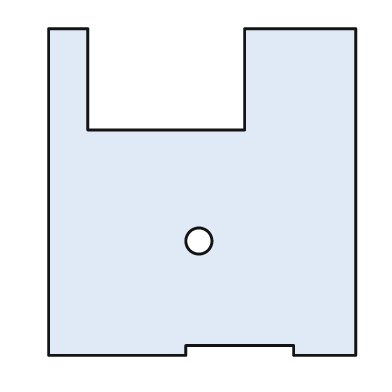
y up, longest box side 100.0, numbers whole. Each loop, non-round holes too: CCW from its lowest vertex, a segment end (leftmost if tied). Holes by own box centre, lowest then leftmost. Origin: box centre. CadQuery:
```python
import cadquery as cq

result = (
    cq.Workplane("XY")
    .moveTo(-47.0, -50.0)
    .lineTo(-5.0, -50.0)
    .lineTo(-5.0, -47.0)
    .lineTo(28.0, -47.0)
    .lineTo(28.0, -50.0)
    .lineTo(47.0, -50.0)
    .lineTo(47.0, 50.0)
    .lineTo(13.0, 50.0)
    .lineTo(13.0, 19.0)
    .lineTo(-35.0, 19.0)
    .lineTo(-35.0, 50.0)
    .lineTo(-47.0, 50.0)
    .close()
    .moveTo(-1.0, -15.0)
    .circle(4.0)
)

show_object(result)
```